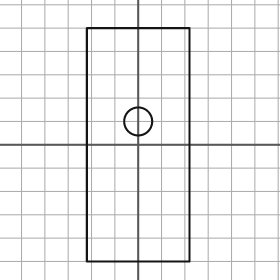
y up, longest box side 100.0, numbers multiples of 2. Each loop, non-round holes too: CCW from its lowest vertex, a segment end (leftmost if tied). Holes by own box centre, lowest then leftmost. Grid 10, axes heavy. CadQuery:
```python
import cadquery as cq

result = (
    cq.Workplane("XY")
    .moveTo(-22.0, -50.0)
    .lineTo(22.0, -50.0)
    .lineTo(22.0, 50.0)
    .lineTo(-22.0, 50.0)
    .close()
    .moveTo(0.0, 10.0)
    .circle(6.0)
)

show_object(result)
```